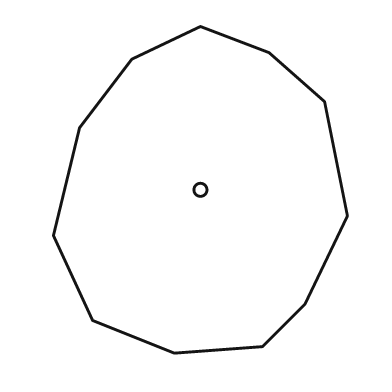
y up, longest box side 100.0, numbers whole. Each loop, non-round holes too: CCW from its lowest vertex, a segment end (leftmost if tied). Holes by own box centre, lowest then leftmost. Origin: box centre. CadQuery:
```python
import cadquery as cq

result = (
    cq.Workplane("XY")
    .moveTo(-8.0, -50.0)
    .lineTo(19.0, -48.0)
    .lineTo(32.0, -35.0)
    .lineTo(45.0, -8.0)
    .lineTo(38.0, 27.0)
    .lineTo(21.0, 42.0)
    .lineTo(0.0, 50.0)
    .lineTo(-21.0, 40.0)
    .lineTo(-37.0, 19.0)
    .lineTo(-45.0, -14.0)
    .lineTo(-33.0, -40.0)
    .close()
    .moveTo(0.0, 0.0)
    .circle(2.0)
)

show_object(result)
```